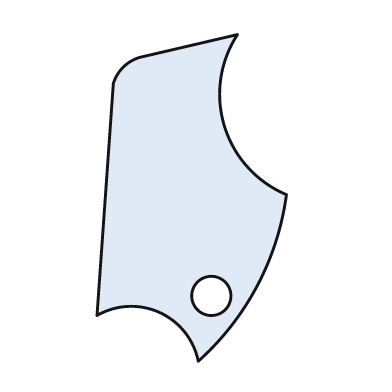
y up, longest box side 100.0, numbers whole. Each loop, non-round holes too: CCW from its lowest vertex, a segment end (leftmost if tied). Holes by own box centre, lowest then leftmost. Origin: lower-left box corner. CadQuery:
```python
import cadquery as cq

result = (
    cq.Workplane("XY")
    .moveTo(31.0, 0.0)
    .threePointArc((49.0, 23.0), (58.0, 51.0))
    .threePointArc((39.0, 72.0), (43.0, 100.0))
    .lineTo(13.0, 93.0)
    .threePointArc((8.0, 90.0), (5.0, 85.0))
    .lineTo(0.0, 14.0)
    .threePointArc((19.0, 15.0), (31.0, 0.0))
    .close()
    .moveTo(35.0, 20.0)
    .circle(6.0)
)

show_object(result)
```